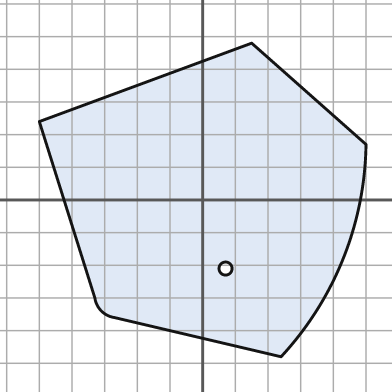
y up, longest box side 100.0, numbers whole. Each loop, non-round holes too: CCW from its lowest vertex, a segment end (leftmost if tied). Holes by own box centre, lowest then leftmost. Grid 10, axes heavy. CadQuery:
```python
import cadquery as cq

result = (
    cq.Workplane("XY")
    .moveTo(24.0, -48.0)
    .threePointArc((43.0, -18.0), (50.0, 17.0))
    .lineTo(15.0, 48.0)
    .lineTo(-50.0, 24.0)
    .lineTo(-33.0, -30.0)
    .threePointArc((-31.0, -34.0), (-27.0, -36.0))
    .close()
    .moveTo(7.0, -21.0)
    .circle(2.0)
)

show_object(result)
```